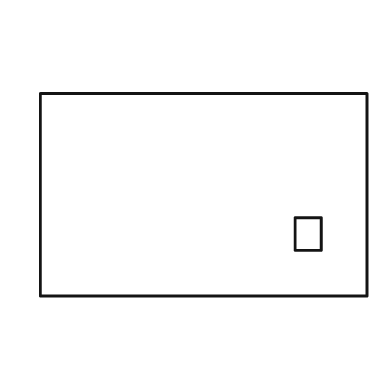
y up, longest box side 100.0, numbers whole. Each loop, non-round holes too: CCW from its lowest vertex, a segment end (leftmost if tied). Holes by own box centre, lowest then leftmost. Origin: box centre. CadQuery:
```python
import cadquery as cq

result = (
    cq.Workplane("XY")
    .moveTo(-50.0, -31.0)
    .lineTo(50.0, -31.0)
    .lineTo(50.0, 31.0)
    .lineTo(-50.0, 31.0)
    .close()
    .moveTo(28.0, -17.0)
    .lineTo(36.0, -17.0)
    .lineTo(36.0, -7.0)
    .lineTo(28.0, -7.0)
    .close()
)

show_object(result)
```